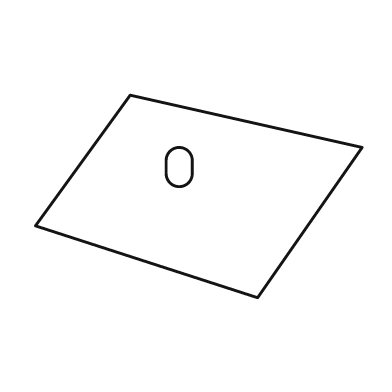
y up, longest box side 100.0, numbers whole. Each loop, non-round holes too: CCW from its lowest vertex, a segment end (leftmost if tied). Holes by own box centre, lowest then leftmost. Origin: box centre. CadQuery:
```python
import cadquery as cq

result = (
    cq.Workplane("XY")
    .moveTo(18.0, -31.0)
    .lineTo(50.0, 15.0)
    .lineTo(-21.0, 31.0)
    .lineTo(-50.0, -9.0)
    .close()
    .moveTo(-10.0, 7.0)
    .threePointArc((-6.0, 3.0), (-2.0, 7.0))
    .lineTo(-2.0, 11.0)
    .threePointArc((-6.0, 15.0), (-10.0, 11.0))
    .close()
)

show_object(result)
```